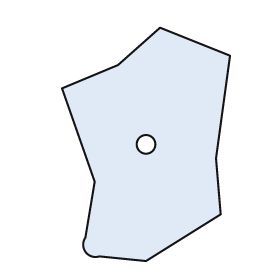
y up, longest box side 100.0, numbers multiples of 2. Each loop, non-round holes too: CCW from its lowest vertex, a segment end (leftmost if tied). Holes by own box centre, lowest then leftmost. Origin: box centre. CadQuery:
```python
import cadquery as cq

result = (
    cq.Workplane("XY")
    .moveTo(0.0, -50.0)
    .lineTo(32.0, -30.0)
    .lineTo(30.0, -6.0)
    .lineTo(36.0, 38.0)
    .lineTo(6.0, 50.0)
    .lineTo(-12.0, 34.0)
    .lineTo(-36.0, 24.0)
    .lineTo(-22.0, -16.0)
    .lineTo(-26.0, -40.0)
    .threePointArc((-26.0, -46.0), (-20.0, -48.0))
    .close()
    .moveTo(0.0, 0.0)
    .circle(4.0)
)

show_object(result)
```